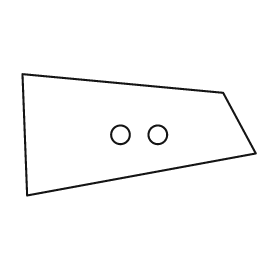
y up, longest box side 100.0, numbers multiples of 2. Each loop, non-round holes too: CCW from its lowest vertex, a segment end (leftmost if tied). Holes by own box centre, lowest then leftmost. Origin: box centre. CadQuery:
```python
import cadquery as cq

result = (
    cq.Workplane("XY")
    .moveTo(-48.0, -26.0)
    .lineTo(50.0, -8.0)
    .lineTo(36.0, 18.0)
    .lineTo(-50.0, 26.0)
    .close()
    .moveTo(-8.0, 0.0)
    .circle(4.0)
    .moveTo(8.0, 0.0)
    .circle(4.0)
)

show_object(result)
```